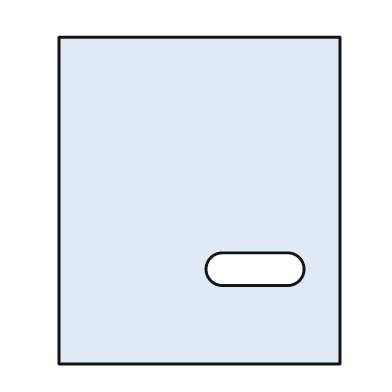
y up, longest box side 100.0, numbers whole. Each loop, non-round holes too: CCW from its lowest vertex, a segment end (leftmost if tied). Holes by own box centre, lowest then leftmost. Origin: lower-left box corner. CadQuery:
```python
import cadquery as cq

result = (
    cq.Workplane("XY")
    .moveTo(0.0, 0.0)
    .lineTo(86.0, 0.0)
    .lineTo(86.0, 100.0)
    .lineTo(0.0, 100.0)
    .close()
    .moveTo(50.0, 24.0)
    .lineTo(70.0, 24.0)
    .threePointArc((75.0, 29.0), (70.0, 34.0))
    .lineTo(50.0, 34.0)
    .threePointArc((45.0, 29.0), (50.0, 24.0))
    .close()
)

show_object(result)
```